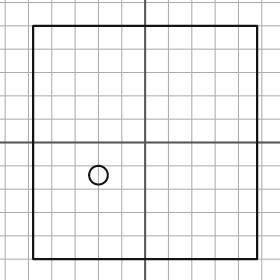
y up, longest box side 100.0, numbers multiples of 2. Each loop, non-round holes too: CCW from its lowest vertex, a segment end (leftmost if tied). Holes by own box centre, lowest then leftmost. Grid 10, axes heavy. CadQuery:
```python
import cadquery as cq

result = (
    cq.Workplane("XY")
    .moveTo(-48.0, -50.0)
    .lineTo(48.0, -50.0)
    .lineTo(48.0, 50.0)
    .lineTo(-48.0, 50.0)
    .close()
    .moveTo(-20.0, -14.0)
    .circle(4.0)
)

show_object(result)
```